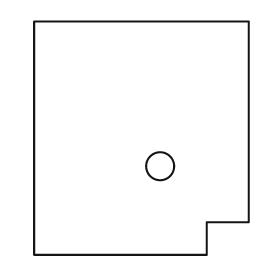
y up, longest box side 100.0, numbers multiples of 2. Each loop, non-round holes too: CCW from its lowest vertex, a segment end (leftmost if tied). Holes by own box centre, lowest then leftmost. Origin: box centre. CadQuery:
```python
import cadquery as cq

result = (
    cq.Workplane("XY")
    .moveTo(-46.0, -50.0)
    .lineTo(28.0, -50.0)
    .lineTo(28.0, -36.0)
    .lineTo(46.0, -36.0)
    .lineTo(46.0, 50.0)
    .lineTo(-46.0, 50.0)
    .close()
    .moveTo(8.0, -12.0)
    .circle(6.0)
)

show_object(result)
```